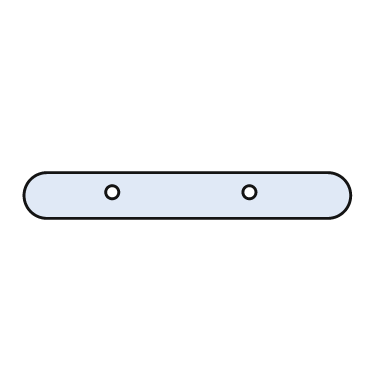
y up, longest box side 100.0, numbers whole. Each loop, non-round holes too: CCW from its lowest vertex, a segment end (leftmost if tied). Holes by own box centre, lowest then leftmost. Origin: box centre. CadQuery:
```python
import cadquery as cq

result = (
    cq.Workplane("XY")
    .moveTo(-43.0, -7.0)
    .lineTo(43.0, -7.0)
    .threePointArc((50.0, 0.0), (43.0, 7.0))
    .lineTo(-43.0, 7.0)
    .threePointArc((-50.0, 0.0), (-43.0, -7.0))
    .close()
    .moveTo(-23.0, 1.0)
    .circle(2.0)
    .moveTo(19.0, 1.0)
    .circle(2.0)
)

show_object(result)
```